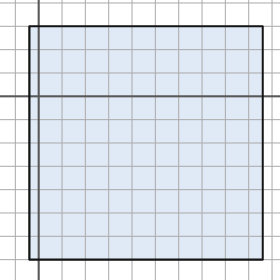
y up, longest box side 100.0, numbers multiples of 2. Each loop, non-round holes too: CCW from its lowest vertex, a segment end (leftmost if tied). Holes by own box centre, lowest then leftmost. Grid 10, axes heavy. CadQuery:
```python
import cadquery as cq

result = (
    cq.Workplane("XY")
    .moveTo(-4.0, -70.0)
    .lineTo(96.0, -70.0)
    .lineTo(96.0, 30.0)
    .lineTo(-4.0, 30.0)
    .close()
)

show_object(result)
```